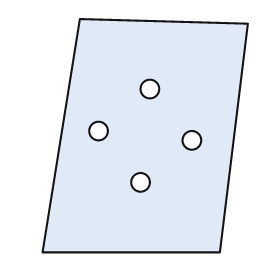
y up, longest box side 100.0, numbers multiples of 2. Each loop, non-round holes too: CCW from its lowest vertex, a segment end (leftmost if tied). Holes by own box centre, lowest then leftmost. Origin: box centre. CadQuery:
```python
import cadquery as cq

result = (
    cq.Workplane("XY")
    .moveTo(-44.0, -50.0)
    .lineTo(32.0, -50.0)
    .lineTo(44.0, 48.0)
    .lineTo(-28.0, 50.0)
    .close()
    .moveTo(-2.0, -20.0)
    .circle(4.0)
    .moveTo(20.0, -2.0)
    .circle(4.0)
    .moveTo(-20.0, 2.0)
    .circle(4.0)
    .moveTo(2.0, 20.0)
    .circle(4.0)
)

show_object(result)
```